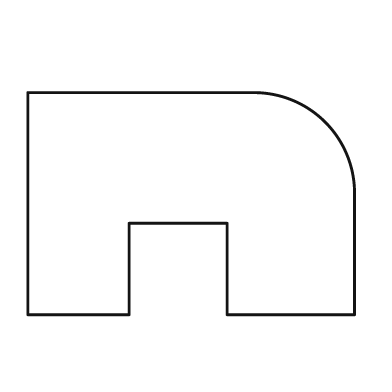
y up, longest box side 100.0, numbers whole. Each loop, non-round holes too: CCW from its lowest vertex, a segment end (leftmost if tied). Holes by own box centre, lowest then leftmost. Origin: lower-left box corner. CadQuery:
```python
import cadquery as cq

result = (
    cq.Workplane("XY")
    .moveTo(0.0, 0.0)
    .lineTo(31.0, 0.0)
    .lineTo(31.0, 28.0)
    .lineTo(61.0, 28.0)
    .lineTo(61.0, 0.0)
    .lineTo(100.0, 0.0)
    .lineTo(100.0, 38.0)
    .threePointArc((91.0, 59.0), (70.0, 68.0))
    .lineTo(0.0, 68.0)
    .close()
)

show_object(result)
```